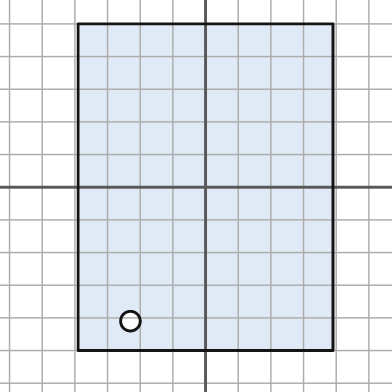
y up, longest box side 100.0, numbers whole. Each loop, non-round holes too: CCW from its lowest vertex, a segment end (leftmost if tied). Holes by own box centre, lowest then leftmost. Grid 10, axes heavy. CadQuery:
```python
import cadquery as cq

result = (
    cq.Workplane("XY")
    .moveTo(-39.0, -50.0)
    .lineTo(39.0, -50.0)
    .lineTo(39.0, 50.0)
    .lineTo(-39.0, 50.0)
    .close()
    .moveTo(-23.0, -41.0)
    .circle(3.0)
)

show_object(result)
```